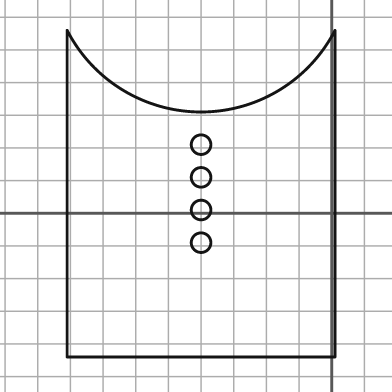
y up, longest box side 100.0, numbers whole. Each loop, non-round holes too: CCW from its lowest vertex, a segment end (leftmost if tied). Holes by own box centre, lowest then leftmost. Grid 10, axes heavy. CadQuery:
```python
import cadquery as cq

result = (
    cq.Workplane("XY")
    .moveTo(-81.0, -44.0)
    .lineTo(1.0, -44.0)
    .lineTo(1.0, 56.0)
    .threePointArc((-40.0, 31.0), (-81.0, 56.0))
    .close()
    .moveTo(-40.0, -9.0)
    .circle(3.0)
    .moveTo(-40.0, 1.0)
    .circle(3.0)
    .moveTo(-40.0, 11.0)
    .circle(3.0)
    .moveTo(-40.0, 21.0)
    .circle(3.0)
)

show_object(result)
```